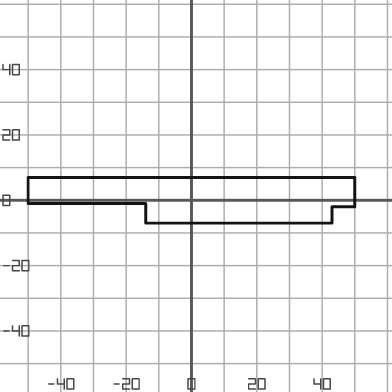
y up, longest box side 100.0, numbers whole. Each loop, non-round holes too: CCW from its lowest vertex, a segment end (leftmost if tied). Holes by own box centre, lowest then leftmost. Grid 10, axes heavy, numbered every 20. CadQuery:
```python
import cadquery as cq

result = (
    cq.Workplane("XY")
    .moveTo(-14.0, -7.0)
    .lineTo(43.0, -7.0)
    .lineTo(43.0, -2.0)
    .lineTo(50.0, -2.0)
    .lineTo(50.0, 7.0)
    .lineTo(-50.0, 7.0)
    .lineTo(-50.0, -1.0)
    .lineTo(-14.0, -1.0)
    .close()
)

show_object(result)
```